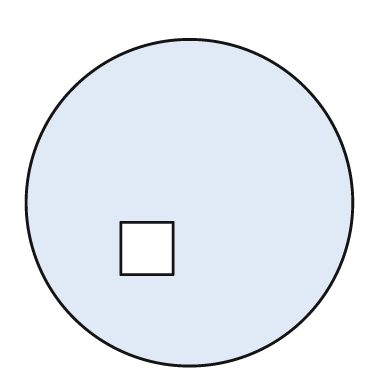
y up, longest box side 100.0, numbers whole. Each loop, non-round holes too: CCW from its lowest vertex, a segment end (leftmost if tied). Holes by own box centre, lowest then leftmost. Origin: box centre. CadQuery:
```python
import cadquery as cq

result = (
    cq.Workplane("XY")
    .moveTo(0.0, 0.0)
    .circle(50.0)
    .moveTo(-21.0, -22.0)
    .lineTo(-5.0, -22.0)
    .lineTo(-5.0, -6.0)
    .lineTo(-21.0, -6.0)
    .close()
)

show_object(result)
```